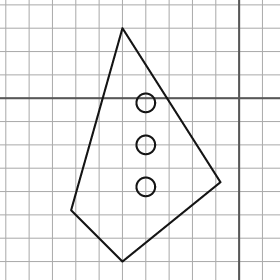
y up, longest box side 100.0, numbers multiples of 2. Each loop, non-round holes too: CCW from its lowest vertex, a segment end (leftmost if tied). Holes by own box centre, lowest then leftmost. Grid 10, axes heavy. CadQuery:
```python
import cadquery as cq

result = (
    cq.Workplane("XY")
    .moveTo(-50.0, -70.0)
    .lineTo(-8.0, -36.0)
    .lineTo(-50.0, 30.0)
    .lineTo(-72.0, -48.0)
    .close()
    .moveTo(-40.0, -38.0)
    .circle(4.0)
    .moveTo(-40.0, -20.0)
    .circle(4.0)
    .moveTo(-40.0, -2.0)
    .circle(4.0)
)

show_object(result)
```